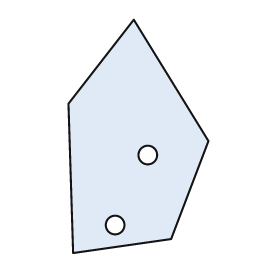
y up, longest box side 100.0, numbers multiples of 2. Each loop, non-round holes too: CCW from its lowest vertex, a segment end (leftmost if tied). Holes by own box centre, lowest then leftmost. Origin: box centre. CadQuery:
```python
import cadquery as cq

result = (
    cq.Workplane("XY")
    .moveTo(-28.0, -50.0)
    .lineTo(14.0, -44.0)
    .lineTo(30.0, -2.0)
    .lineTo(-2.0, 50.0)
    .lineTo(-30.0, 14.0)
    .close()
    .moveTo(-10.0, -38.0)
    .circle(4.0)
    .moveTo(4.0, -8.0)
    .circle(4.0)
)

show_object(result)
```